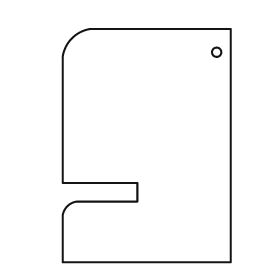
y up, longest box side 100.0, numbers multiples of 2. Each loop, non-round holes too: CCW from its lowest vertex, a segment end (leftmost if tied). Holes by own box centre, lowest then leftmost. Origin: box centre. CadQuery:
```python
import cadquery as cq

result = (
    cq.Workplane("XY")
    .moveTo(-36.0, -50.0)
    .lineTo(36.0, -50.0)
    .lineTo(36.0, 50.0)
    .lineTo(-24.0, 50.0)
    .threePointArc((-32.0, 46.0), (-36.0, 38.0))
    .lineTo(-36.0, -16.0)
    .lineTo(-4.0, -16.0)
    .lineTo(-4.0, -24.0)
    .lineTo(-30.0, -24.0)
    .threePointArc((-34.0, -26.0), (-36.0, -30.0))
    .close()
    .moveTo(30.0, 40.0)
    .circle(2.0)
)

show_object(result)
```